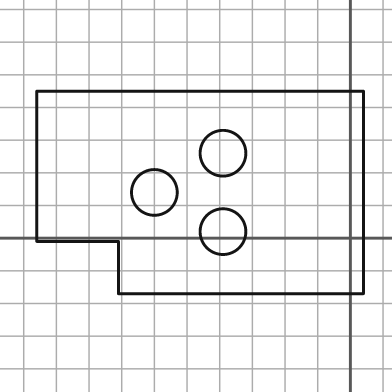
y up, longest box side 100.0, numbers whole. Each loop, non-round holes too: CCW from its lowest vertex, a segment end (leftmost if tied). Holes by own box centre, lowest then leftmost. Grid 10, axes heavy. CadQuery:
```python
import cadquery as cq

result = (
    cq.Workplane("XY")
    .moveTo(-71.0, -17.0)
    .lineTo(4.0, -17.0)
    .lineTo(4.0, 45.0)
    .lineTo(-96.0, 45.0)
    .lineTo(-96.0, -1.0)
    .lineTo(-71.0, -1.0)
    .close()
    .moveTo(-39.0, 2.0)
    .circle(7.0)
    .moveTo(-60.0, 14.0)
    .circle(7.0)
    .moveTo(-39.0, 26.0)
    .circle(7.0)
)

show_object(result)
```